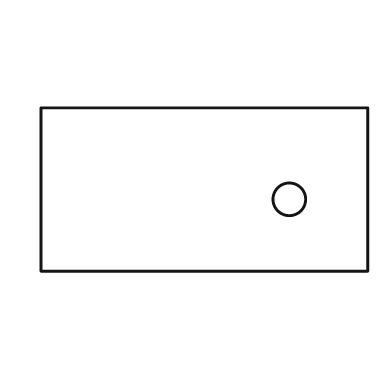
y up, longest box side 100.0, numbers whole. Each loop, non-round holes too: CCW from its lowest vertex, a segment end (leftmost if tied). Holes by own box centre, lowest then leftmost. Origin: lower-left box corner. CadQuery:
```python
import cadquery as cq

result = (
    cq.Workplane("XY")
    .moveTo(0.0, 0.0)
    .lineTo(100.0, 0.0)
    .lineTo(100.0, 50.0)
    .lineTo(0.0, 50.0)
    .close()
    .moveTo(76.0, 22.0)
    .circle(5.0)
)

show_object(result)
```